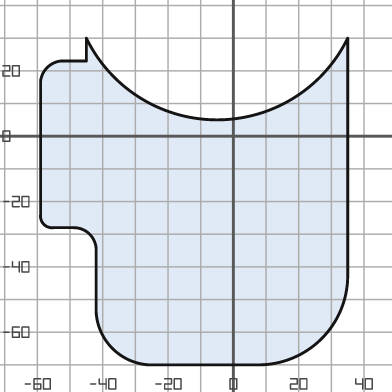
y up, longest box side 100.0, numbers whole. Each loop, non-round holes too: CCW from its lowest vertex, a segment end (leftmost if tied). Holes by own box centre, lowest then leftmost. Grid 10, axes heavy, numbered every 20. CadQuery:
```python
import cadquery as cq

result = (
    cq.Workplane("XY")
    .moveTo(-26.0, -70.0)
    .lineTo(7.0, -70.0)
    .threePointArc((27.0, -62.0), (35.0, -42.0))
    .lineTo(35.0, 30.0)
    .threePointArc((-5.0, 5.0), (-45.0, 30.0))
    .lineTo(-45.0, 23.0)
    .lineTo(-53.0, 23.0)
    .threePointArc((-57.0, 21.0), (-59.0, 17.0))
    .lineTo(-59.0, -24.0)
    .threePointArc((-58.0, -27.0), (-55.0, -28.0))
    .lineTo(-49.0, -28.0)
    .threePointArc((-44.0, -30.0), (-42.0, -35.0))
    .lineTo(-42.0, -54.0)
    .threePointArc((-37.0, -65.0), (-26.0, -70.0))
    .close()
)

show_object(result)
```